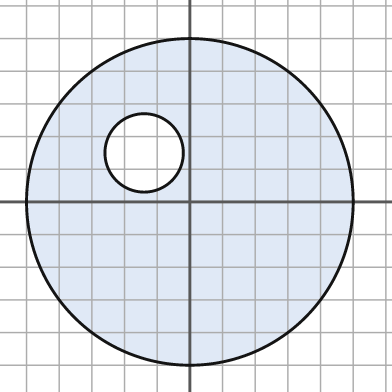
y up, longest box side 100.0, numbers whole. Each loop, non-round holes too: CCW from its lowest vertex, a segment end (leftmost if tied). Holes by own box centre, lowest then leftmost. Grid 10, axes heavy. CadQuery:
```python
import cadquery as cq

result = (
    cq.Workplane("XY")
    .moveTo(0.0, 0.0)
    .circle(50.0)
    .moveTo(-14.0, 15.0)
    .circle(12.0)
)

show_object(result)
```